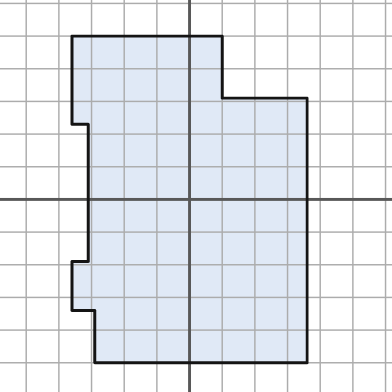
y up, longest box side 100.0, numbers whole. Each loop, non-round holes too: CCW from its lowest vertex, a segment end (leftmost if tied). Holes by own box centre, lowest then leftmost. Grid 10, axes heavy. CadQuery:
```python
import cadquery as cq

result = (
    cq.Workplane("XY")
    .moveTo(-29.0, -50.0)
    .lineTo(36.0, -50.0)
    .lineTo(36.0, 31.0)
    .lineTo(10.0, 31.0)
    .lineTo(10.0, 50.0)
    .lineTo(-36.0, 50.0)
    .lineTo(-36.0, 23.0)
    .lineTo(-31.0, 23.0)
    .lineTo(-31.0, -19.0)
    .lineTo(-36.0, -19.0)
    .lineTo(-36.0, -34.0)
    .lineTo(-29.0, -34.0)
    .close()
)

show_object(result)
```